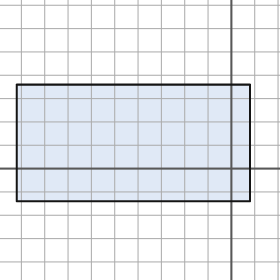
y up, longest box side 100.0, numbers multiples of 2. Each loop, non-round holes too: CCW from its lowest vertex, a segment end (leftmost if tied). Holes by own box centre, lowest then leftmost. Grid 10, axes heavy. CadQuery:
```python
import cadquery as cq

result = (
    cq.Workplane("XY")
    .moveTo(-92.0, -14.0)
    .lineTo(8.0, -14.0)
    .lineTo(8.0, 36.0)
    .lineTo(-92.0, 36.0)
    .close()
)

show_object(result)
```